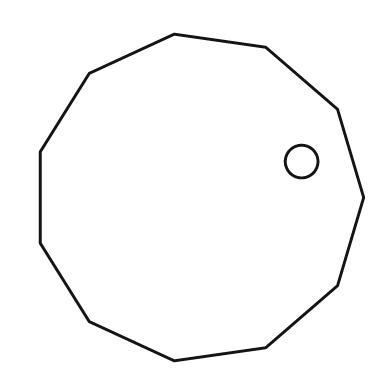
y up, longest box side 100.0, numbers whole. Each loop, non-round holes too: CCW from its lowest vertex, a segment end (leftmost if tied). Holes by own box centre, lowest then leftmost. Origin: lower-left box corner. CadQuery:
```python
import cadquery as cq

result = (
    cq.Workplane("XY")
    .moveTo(41.0, 0.0)
    .lineTo(69.0, 4.0)
    .lineTo(91.0, 23.0)
    .lineTo(99.0, 50.0)
    .lineTo(91.0, 77.0)
    .lineTo(69.0, 96.0)
    .lineTo(41.0, 100.0)
    .lineTo(15.0, 88.0)
    .lineTo(0.0, 64.0)
    .lineTo(0.0, 36.0)
    .lineTo(15.0, 12.0)
    .close()
    .moveTo(80.0, 61.0)
    .circle(5.0)
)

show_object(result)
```